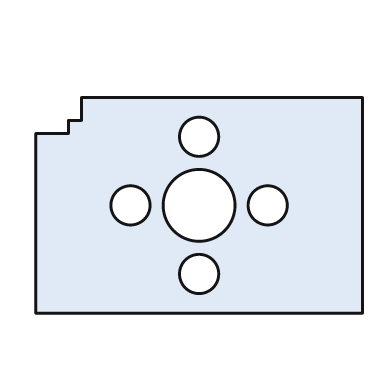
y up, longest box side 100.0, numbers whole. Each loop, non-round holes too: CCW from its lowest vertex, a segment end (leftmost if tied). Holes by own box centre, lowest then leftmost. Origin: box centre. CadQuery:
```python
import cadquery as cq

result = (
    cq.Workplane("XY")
    .moveTo(-50.0, -33.0)
    .lineTo(50.0, -33.0)
    .lineTo(50.0, 33.0)
    .lineTo(-36.0, 33.0)
    .lineTo(-36.0, 26.0)
    .lineTo(-40.0, 26.0)
    .lineTo(-40.0, 22.0)
    .lineTo(-50.0, 22.0)
    .close()
    .moveTo(0.0, -21.0)
    .circle(6.0)
    .moveTo(-21.0, 0.0)
    .circle(6.0)
    .moveTo(0.0, 0.0)
    .circle(11.0)
    .moveTo(21.0, 0.0)
    .circle(6.0)
    .moveTo(0.0, 21.0)
    .circle(6.0)
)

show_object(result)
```